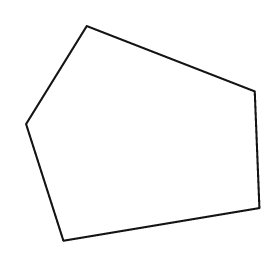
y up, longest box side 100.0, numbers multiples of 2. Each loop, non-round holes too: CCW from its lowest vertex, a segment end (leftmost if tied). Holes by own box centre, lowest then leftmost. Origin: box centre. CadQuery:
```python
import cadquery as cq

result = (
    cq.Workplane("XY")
    .moveTo(-34.0, -46.0)
    .lineTo(50.0, -32.0)
    .lineTo(48.0, 18.0)
    .lineTo(-24.0, 46.0)
    .lineTo(-50.0, 4.0)
    .close()
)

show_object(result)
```